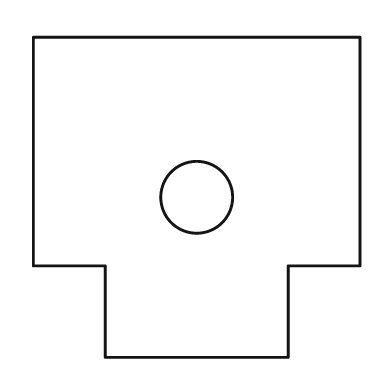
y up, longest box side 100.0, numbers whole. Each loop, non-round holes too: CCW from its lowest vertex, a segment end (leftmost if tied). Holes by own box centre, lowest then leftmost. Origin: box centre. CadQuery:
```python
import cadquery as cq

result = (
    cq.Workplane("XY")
    .moveTo(-28.0, -49.0)
    .lineTo(28.0, -49.0)
    .lineTo(28.0, -21.0)
    .lineTo(50.0, -21.0)
    .lineTo(50.0, 49.0)
    .lineTo(-50.0, 49.0)
    .lineTo(-50.0, -21.0)
    .lineTo(-28.0, -21.0)
    .close()
    .moveTo(0.0, 0.0)
    .circle(11.0)
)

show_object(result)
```